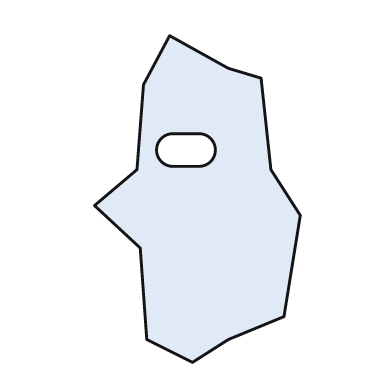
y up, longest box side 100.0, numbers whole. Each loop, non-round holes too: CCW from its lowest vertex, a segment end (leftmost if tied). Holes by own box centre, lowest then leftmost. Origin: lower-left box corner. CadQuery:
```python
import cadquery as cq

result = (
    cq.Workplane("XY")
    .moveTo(30.0, 0.0)
    .lineTo(41.0, 7.0)
    .lineTo(58.0, 14.0)
    .lineTo(63.0, 45.0)
    .lineTo(54.0, 59.0)
    .lineTo(51.0, 87.0)
    .lineTo(41.0, 90.0)
    .lineTo(23.0, 100.0)
    .lineTo(15.0, 85.0)
    .lineTo(13.0, 59.0)
    .lineTo(0.0, 48.0)
    .lineTo(14.0, 35.0)
    .lineTo(16.0, 7.0)
    .close()
    .moveTo(24.0, 60.0)
    .lineTo(32.0, 60.0)
    .threePointArc((37.0, 65.0), (32.0, 70.0))
    .lineTo(24.0, 70.0)
    .threePointArc((19.0, 65.0), (24.0, 60.0))
    .close()
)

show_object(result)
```